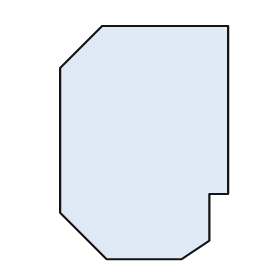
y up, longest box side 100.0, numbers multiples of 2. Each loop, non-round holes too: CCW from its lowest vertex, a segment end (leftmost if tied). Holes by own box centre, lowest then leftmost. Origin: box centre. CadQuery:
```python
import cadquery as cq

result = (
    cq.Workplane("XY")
    .moveTo(-16.0, -50.0)
    .lineTo(16.0, -50.0)
    .lineTo(28.0, -42.0)
    .lineTo(28.0, -22.0)
    .lineTo(36.0, -22.0)
    .lineTo(36.0, 50.0)
    .lineTo(-18.0, 50.0)
    .lineTo(-36.0, 32.0)
    .lineTo(-36.0, -30.0)
    .close()
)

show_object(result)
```